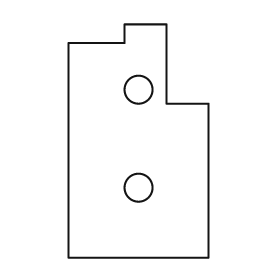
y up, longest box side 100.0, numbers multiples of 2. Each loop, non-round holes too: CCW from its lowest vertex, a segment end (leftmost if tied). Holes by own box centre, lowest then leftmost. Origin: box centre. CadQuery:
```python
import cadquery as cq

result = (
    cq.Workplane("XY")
    .moveTo(-30.0, -50.0)
    .lineTo(30.0, -50.0)
    .lineTo(30.0, 16.0)
    .lineTo(12.0, 16.0)
    .lineTo(12.0, 50.0)
    .lineTo(-6.0, 50.0)
    .lineTo(-6.0, 42.0)
    .lineTo(-30.0, 42.0)
    .close()
    .moveTo(0.0, -20.0)
    .circle(6.0)
    .moveTo(0.0, 22.0)
    .circle(6.0)
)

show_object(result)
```